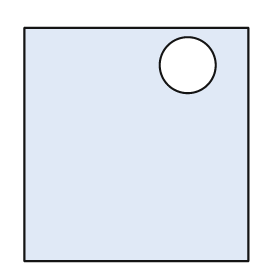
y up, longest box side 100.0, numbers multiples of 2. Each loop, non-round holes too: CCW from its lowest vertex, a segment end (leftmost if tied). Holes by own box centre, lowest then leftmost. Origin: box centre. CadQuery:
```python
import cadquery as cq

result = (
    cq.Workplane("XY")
    .moveTo(-48.0, -50.0)
    .lineTo(48.0, -50.0)
    .lineTo(48.0, 50.0)
    .lineTo(-48.0, 50.0)
    .close()
    .moveTo(22.0, 34.0)
    .circle(12.0)
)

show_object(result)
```